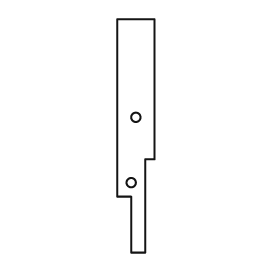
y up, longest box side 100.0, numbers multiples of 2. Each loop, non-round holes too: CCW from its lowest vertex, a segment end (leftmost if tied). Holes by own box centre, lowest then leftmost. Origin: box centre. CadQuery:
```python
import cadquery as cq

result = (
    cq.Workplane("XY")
    .moveTo(-2.0, -50.0)
    .lineTo(4.0, -50.0)
    .lineTo(4.0, -10.0)
    .lineTo(8.0, -10.0)
    .lineTo(8.0, 50.0)
    .lineTo(-8.0, 50.0)
    .lineTo(-8.0, -26.0)
    .lineTo(-2.0, -26.0)
    .close()
    .moveTo(-2.0, -20.0)
    .circle(2.0)
    .moveTo(0.0, 8.0)
    .circle(2.0)
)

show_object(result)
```